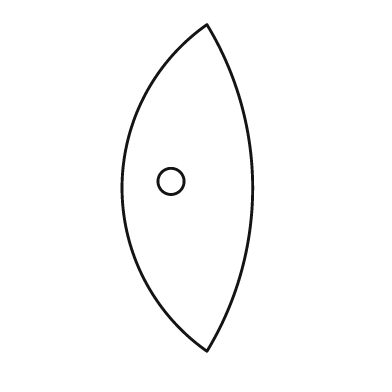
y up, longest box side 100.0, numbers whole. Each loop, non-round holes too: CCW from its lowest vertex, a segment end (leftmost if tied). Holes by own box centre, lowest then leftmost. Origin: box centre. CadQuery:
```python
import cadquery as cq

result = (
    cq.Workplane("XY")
    .moveTo(6.0, -50.0)
    .threePointArc((20.0, 0.0), (6.0, 50.0))
    .threePointArc((-20.0, 0.0), (6.0, -50.0))
    .close()
    .moveTo(-5.0, 2.0)
    .circle(4.0)
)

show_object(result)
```